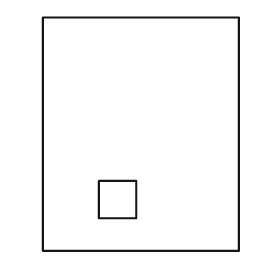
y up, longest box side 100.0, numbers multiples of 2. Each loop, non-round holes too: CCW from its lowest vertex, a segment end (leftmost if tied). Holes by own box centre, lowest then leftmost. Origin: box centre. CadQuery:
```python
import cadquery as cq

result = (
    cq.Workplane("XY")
    .moveTo(-42.0, -50.0)
    .lineTo(42.0, -50.0)
    .lineTo(42.0, 50.0)
    .lineTo(-42.0, 50.0)
    .close()
    .moveTo(-18.0, -36.0)
    .lineTo(-2.0, -36.0)
    .lineTo(-2.0, -20.0)
    .lineTo(-18.0, -20.0)
    .close()
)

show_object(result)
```